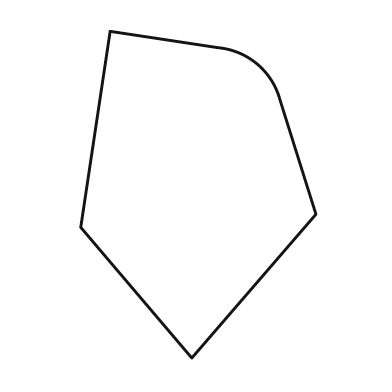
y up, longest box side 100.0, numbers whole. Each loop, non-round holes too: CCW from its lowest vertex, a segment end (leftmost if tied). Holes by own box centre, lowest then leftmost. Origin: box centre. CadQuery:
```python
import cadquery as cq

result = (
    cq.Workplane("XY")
    .moveTo(-2.0, -50.0)
    .lineTo(36.0, -6.0)
    .lineTo(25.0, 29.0)
    .threePointArc((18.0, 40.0), (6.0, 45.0))
    .lineTo(-27.0, 50.0)
    .lineTo(-36.0, -10.0)
    .close()
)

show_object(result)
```